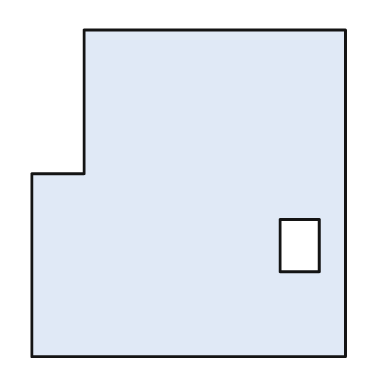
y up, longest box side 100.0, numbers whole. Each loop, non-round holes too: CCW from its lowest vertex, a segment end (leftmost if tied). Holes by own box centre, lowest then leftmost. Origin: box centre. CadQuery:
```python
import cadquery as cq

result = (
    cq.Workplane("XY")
    .moveTo(-48.0, -50.0)
    .lineTo(48.0, -50.0)
    .lineTo(48.0, 50.0)
    .lineTo(-32.0, 50.0)
    .lineTo(-32.0, 6.0)
    .lineTo(-48.0, 6.0)
    .close()
    .moveTo(28.0, -24.0)
    .lineTo(40.0, -24.0)
    .lineTo(40.0, -8.0)
    .lineTo(28.0, -8.0)
    .close()
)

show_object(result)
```